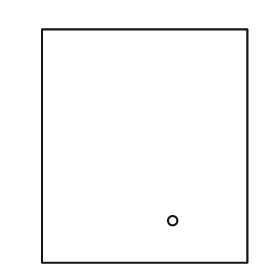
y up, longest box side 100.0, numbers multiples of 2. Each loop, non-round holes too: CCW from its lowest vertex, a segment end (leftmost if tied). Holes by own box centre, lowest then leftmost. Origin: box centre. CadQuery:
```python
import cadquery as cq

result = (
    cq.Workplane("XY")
    .moveTo(-44.0, -50.0)
    .lineTo(44.0, -50.0)
    .lineTo(44.0, 50.0)
    .lineTo(-44.0, 50.0)
    .close()
    .moveTo(12.0, -32.0)
    .circle(2.0)
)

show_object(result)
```